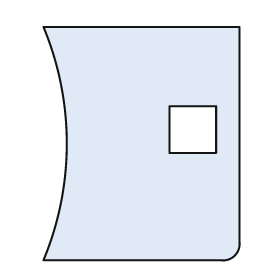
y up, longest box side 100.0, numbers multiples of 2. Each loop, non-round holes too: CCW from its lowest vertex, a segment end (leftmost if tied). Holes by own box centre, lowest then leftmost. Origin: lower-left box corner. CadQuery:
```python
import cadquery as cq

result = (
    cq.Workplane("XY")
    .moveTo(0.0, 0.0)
    .lineTo(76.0, 0.0)
    .threePointArc((82.0, 2.0), (84.0, 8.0))
    .lineTo(84.0, 100.0)
    .lineTo(0.0, 100.0)
    .threePointArc((10.0, 50.0), (0.0, 0.0))
    .close()
    .moveTo(54.0, 46.0)
    .lineTo(74.0, 46.0)
    .lineTo(74.0, 66.0)
    .lineTo(54.0, 66.0)
    .close()
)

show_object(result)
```